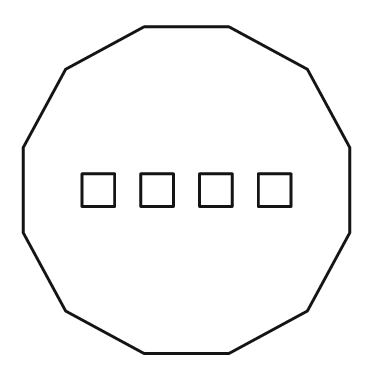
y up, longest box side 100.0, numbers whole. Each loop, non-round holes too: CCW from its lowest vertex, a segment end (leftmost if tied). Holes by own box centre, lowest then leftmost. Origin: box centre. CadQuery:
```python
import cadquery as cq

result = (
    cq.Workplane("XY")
    .moveTo(-13.0, -50.0)
    .lineTo(13.0, -50.0)
    .lineTo(37.0, -37.0)
    .lineTo(50.0, -13.0)
    .lineTo(50.0, 13.0)
    .lineTo(37.0, 37.0)
    .lineTo(13.0, 50.0)
    .lineTo(-13.0, 50.0)
    .lineTo(-37.0, 37.0)
    .lineTo(-50.0, 13.0)
    .lineTo(-50.0, -13.0)
    .lineTo(-37.0, -37.0)
    .close()
    .moveTo(-32.0, -5.0)
    .lineTo(-22.0, -5.0)
    .lineTo(-22.0, 5.0)
    .lineTo(-32.0, 5.0)
    .close()
    .moveTo(-14.0, -5.0)
    .lineTo(-4.0, -5.0)
    .lineTo(-4.0, 5.0)
    .lineTo(-14.0, 5.0)
    .close()
    .moveTo(4.0, -5.0)
    .lineTo(14.0, -5.0)
    .lineTo(14.0, 5.0)
    .lineTo(4.0, 5.0)
    .close()
    .moveTo(22.0, -5.0)
    .lineTo(32.0, -5.0)
    .lineTo(32.0, 5.0)
    .lineTo(22.0, 5.0)
    .close()
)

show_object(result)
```